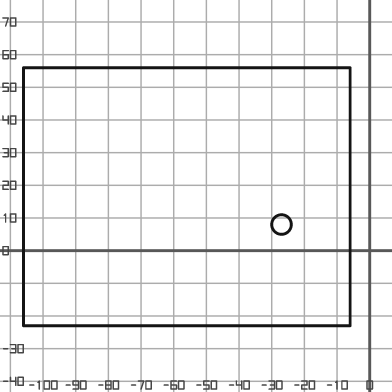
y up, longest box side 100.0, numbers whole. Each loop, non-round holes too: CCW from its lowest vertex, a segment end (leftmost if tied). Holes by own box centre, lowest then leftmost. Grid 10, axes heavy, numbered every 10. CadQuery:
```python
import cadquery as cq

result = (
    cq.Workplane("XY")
    .moveTo(-106.0, -23.0)
    .lineTo(-6.0, -23.0)
    .lineTo(-6.0, 56.0)
    .lineTo(-106.0, 56.0)
    .close()
    .moveTo(-27.0, 8.0)
    .circle(3.0)
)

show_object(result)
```